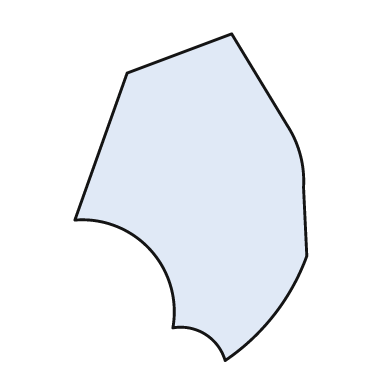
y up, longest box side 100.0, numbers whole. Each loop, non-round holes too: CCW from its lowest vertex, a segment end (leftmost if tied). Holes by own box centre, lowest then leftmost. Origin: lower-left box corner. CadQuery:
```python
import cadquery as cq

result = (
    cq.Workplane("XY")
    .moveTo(46.0, 0.0)
    .threePointArc((61.0, 14.0), (71.0, 32.0))
    .lineTo(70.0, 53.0)
    .threePointArc((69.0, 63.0), (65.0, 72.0))
    .lineTo(48.0, 100.0)
    .lineTo(16.0, 88.0)
    .lineTo(0.0, 43.0)
    .threePointArc((23.0, 34.0), (30.0, 10.0))
    .threePointArc((40.0, 8.0), (46.0, 0.0))
    .close()
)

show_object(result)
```